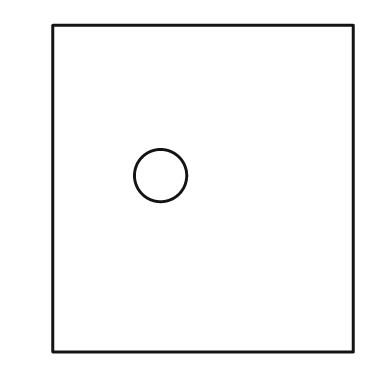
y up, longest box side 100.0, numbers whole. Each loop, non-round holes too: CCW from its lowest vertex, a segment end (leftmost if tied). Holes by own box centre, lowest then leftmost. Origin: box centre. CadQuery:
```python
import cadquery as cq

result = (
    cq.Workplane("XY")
    .moveTo(-46.0, -50.0)
    .lineTo(46.0, -50.0)
    .lineTo(46.0, 50.0)
    .lineTo(-46.0, 50.0)
    .close()
    .moveTo(-13.0, 4.0)
    .circle(8.0)
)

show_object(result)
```